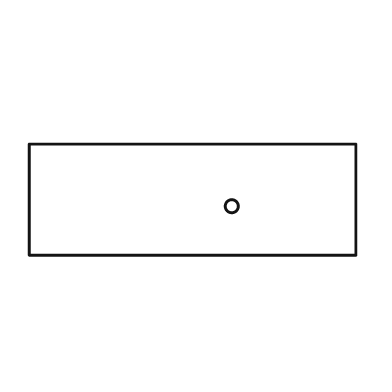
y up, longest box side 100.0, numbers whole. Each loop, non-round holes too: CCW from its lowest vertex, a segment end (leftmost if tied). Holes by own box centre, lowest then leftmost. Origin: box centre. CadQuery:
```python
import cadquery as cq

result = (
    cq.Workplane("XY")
    .moveTo(-50.0, -17.0)
    .lineTo(50.0, -17.0)
    .lineTo(50.0, 17.0)
    .lineTo(-50.0, 17.0)
    .close()
    .moveTo(12.0, -2.0)
    .circle(2.0)
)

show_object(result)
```